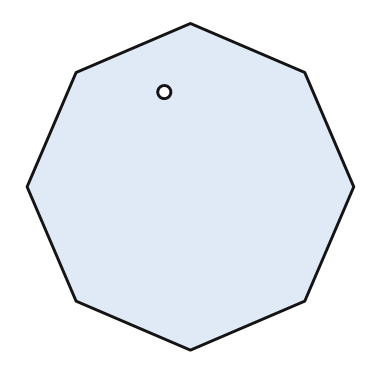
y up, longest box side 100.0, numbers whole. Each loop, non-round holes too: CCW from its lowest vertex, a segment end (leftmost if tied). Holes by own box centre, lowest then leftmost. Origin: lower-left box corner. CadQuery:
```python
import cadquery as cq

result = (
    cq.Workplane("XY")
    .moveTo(50.0, 0.0)
    .lineTo(85.0, 15.0)
    .lineTo(100.0, 50.0)
    .lineTo(85.0, 85.0)
    .lineTo(50.0, 100.0)
    .lineTo(15.0, 85.0)
    .lineTo(0.0, 50.0)
    .lineTo(15.0, 15.0)
    .close()
    .moveTo(42.0, 79.0)
    .circle(2.0)
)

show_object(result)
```